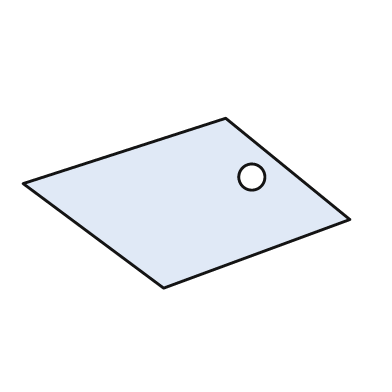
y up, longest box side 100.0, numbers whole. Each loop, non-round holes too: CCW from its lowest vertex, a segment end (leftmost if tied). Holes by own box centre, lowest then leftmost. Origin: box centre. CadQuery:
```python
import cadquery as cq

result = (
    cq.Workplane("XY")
    .moveTo(-7.0, -26.0)
    .lineTo(50.0, -5.0)
    .lineTo(12.0, 26.0)
    .lineTo(-50.0, 6.0)
    .close()
    .moveTo(20.0, 8.0)
    .circle(4.0)
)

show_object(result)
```